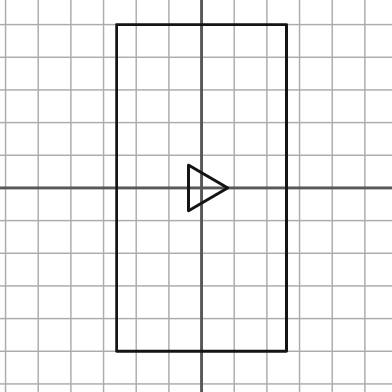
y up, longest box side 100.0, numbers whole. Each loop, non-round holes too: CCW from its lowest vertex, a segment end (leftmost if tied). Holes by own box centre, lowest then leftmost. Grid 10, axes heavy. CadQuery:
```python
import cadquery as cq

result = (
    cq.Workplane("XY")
    .moveTo(-26.0, -50.0)
    .lineTo(26.0, -50.0)
    .lineTo(26.0, 50.0)
    .lineTo(-26.0, 50.0)
    .close()
    .moveTo(-4.0, -7.0)
    .lineTo(8.0, 0.0)
    .lineTo(-4.0, 7.0)
    .close()
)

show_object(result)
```